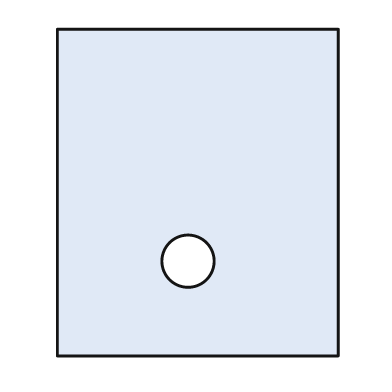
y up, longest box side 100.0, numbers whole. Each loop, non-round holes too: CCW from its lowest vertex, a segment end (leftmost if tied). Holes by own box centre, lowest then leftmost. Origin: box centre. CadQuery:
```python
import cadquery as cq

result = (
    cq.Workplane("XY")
    .moveTo(-43.0, -50.0)
    .lineTo(43.0, -50.0)
    .lineTo(43.0, 50.0)
    .lineTo(-43.0, 50.0)
    .close()
    .moveTo(-3.0, -21.0)
    .circle(8.0)
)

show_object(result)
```